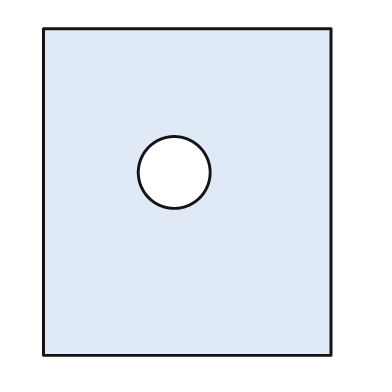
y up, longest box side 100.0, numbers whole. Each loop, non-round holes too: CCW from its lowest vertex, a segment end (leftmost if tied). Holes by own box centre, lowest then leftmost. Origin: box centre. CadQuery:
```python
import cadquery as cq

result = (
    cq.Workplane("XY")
    .moveTo(-44.0, -50.0)
    .lineTo(44.0, -50.0)
    .lineTo(44.0, 50.0)
    .lineTo(-44.0, 50.0)
    .close()
    .moveTo(-4.0, 6.0)
    .circle(11.0)
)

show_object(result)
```